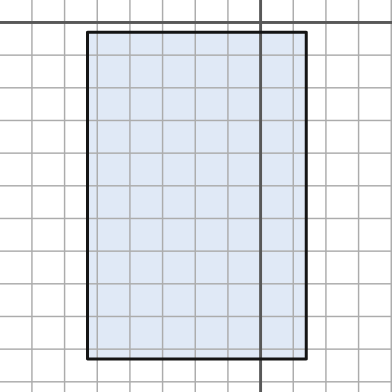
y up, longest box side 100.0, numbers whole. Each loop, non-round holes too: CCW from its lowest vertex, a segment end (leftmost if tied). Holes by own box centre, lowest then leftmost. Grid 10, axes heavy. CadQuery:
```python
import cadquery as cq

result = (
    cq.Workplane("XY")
    .moveTo(-53.0, -103.0)
    .lineTo(14.0, -103.0)
    .lineTo(14.0, -3.0)
    .lineTo(-53.0, -3.0)
    .close()
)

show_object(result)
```